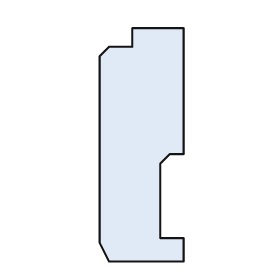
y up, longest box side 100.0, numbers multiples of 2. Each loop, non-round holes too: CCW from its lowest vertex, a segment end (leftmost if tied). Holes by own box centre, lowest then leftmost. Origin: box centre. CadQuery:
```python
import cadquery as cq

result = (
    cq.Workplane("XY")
    .moveTo(-14.0, -50.0)
    .lineTo(18.0, -50.0)
    .lineTo(18.0, -40.0)
    .lineTo(8.0, -40.0)
    .lineTo(8.0, -8.0)
    .lineTo(12.0, -4.0)
    .lineTo(18.0, -4.0)
    .lineTo(18.0, 50.0)
    .lineTo(-4.0, 50.0)
    .lineTo(-4.0, 42.0)
    .lineTo(-14.0, 42.0)
    .lineTo(-18.0, 38.0)
    .lineTo(-18.0, -42.0)
    .close()
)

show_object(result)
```